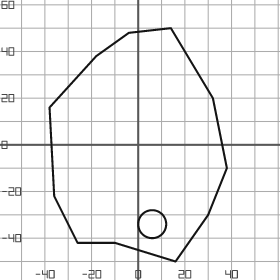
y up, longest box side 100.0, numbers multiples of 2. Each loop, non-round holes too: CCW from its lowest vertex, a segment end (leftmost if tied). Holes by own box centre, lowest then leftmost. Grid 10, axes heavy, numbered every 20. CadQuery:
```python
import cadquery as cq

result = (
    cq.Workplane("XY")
    .moveTo(16.0, -50.0)
    .lineTo(30.0, -30.0)
    .lineTo(38.0, -10.0)
    .lineTo(32.0, 20.0)
    .lineTo(14.0, 50.0)
    .lineTo(-4.0, 48.0)
    .lineTo(-18.0, 38.0)
    .lineTo(-38.0, 16.0)
    .lineTo(-36.0, -22.0)
    .lineTo(-26.0, -42.0)
    .lineTo(-10.0, -42.0)
    .close()
    .moveTo(6.0, -34.0)
    .circle(6.0)
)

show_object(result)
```